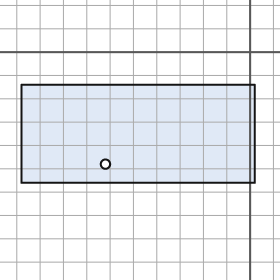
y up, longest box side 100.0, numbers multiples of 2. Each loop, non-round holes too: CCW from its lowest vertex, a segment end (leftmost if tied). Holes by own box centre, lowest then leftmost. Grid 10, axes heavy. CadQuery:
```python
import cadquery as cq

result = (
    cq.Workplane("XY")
    .moveTo(-98.0, -56.0)
    .lineTo(2.0, -56.0)
    .lineTo(2.0, -14.0)
    .lineTo(-98.0, -14.0)
    .close()
    .moveTo(-62.0, -48.0)
    .circle(2.0)
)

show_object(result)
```